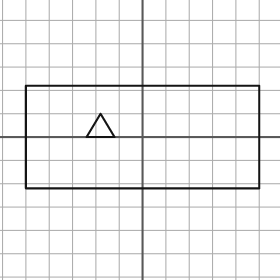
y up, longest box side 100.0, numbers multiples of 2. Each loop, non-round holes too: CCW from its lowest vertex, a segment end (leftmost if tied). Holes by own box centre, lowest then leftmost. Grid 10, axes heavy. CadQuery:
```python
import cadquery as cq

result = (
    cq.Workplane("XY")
    .moveTo(-50.0, -22.0)
    .lineTo(50.0, -22.0)
    .lineTo(50.0, 22.0)
    .lineTo(-50.0, 22.0)
    .close()
    .moveTo(-24.0, 0.0)
    .lineTo(-12.0, 0.0)
    .lineTo(-18.0, 10.0)
    .close()
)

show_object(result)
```